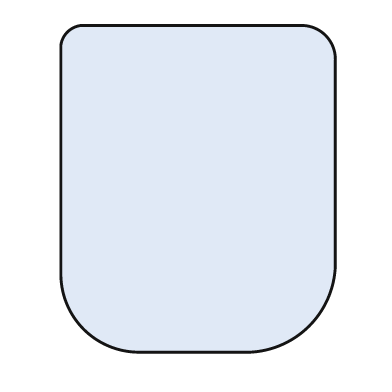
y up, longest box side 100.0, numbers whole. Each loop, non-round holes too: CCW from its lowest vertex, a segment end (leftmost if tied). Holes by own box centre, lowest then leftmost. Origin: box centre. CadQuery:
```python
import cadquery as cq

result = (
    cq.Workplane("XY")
    .moveTo(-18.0, -50.0)
    .lineTo(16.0, -50.0)
    .threePointArc((34.0, -42.0), (42.0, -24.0))
    .lineTo(42.0, 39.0)
    .threePointArc((39.0, 47.0), (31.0, 50.0))
    .lineTo(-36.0, 50.0)
    .threePointArc((-40.0, 48.0), (-42.0, 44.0))
    .lineTo(-42.0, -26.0)
    .threePointArc((-35.0, -43.0), (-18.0, -50.0))
    .close()
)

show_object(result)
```